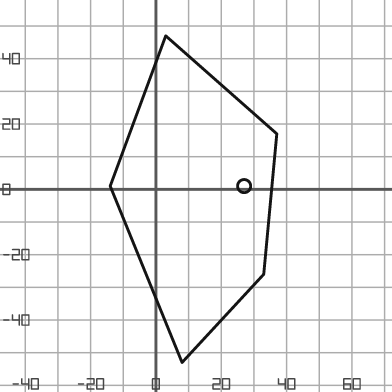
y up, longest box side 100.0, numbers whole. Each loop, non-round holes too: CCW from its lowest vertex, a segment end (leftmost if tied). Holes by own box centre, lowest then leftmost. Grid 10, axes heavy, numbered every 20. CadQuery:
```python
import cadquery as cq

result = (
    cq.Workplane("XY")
    .moveTo(8.0, -53.0)
    .lineTo(33.0, -26.0)
    .lineTo(37.0, 17.0)
    .lineTo(3.0, 47.0)
    .lineTo(-14.0, 1.0)
    .close()
    .moveTo(27.0, 1.0)
    .circle(2.0)
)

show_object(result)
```